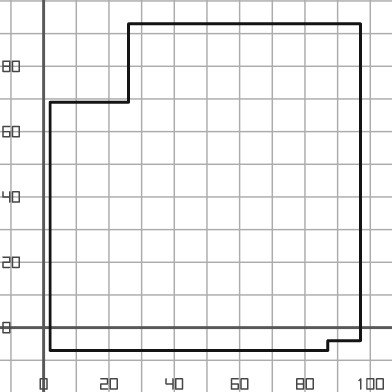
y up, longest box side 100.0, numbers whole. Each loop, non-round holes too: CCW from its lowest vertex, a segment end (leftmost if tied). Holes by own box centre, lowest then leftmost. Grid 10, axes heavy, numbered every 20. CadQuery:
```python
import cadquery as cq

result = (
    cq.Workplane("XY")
    .moveTo(2.0, -7.0)
    .lineTo(87.0, -7.0)
    .lineTo(87.0, -4.0)
    .lineTo(97.0, -4.0)
    .lineTo(97.0, 93.0)
    .lineTo(26.0, 93.0)
    .lineTo(26.0, 69.0)
    .lineTo(2.0, 69.0)
    .close()
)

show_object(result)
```